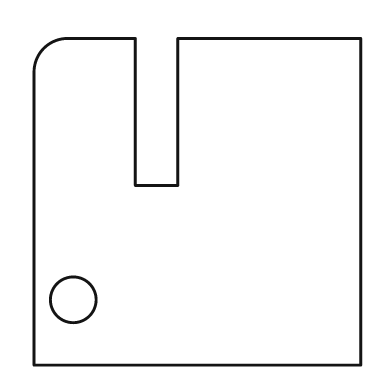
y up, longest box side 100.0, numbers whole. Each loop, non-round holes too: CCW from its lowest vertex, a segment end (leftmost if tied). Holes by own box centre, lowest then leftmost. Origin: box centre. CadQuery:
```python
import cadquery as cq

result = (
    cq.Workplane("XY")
    .moveTo(-50.0, -50.0)
    .lineTo(50.0, -50.0)
    .lineTo(50.0, 50.0)
    .lineTo(-6.0, 50.0)
    .lineTo(-6.0, 5.0)
    .lineTo(-19.0, 5.0)
    .lineTo(-19.0, 50.0)
    .lineTo(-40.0, 50.0)
    .threePointArc((-47.0, 47.0), (-50.0, 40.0))
    .close()
    .moveTo(-38.0, -30.0)
    .circle(7.0)
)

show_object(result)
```